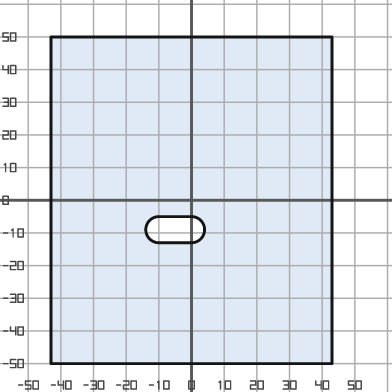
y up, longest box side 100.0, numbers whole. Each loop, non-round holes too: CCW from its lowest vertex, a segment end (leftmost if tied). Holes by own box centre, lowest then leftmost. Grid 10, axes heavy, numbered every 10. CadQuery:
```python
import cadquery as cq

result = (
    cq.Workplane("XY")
    .moveTo(-43.0, -50.0)
    .lineTo(43.0, -50.0)
    .lineTo(43.0, 50.0)
    .lineTo(-43.0, 50.0)
    .close()
    .moveTo(-10.0, -13.0)
    .lineTo(0.0, -13.0)
    .threePointArc((4.0, -9.0), (0.0, -5.0))
    .lineTo(-10.0, -5.0)
    .threePointArc((-14.0, -9.0), (-10.0, -13.0))
    .close()
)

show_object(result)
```